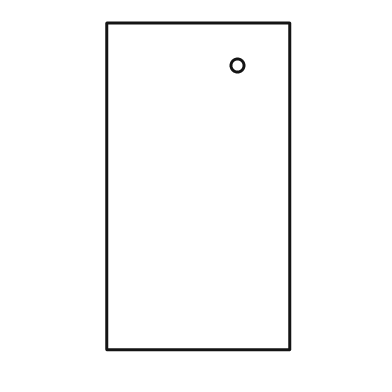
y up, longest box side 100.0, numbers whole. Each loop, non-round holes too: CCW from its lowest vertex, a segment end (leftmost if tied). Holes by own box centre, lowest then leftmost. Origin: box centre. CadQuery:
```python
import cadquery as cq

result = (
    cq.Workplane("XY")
    .moveTo(-28.0, -50.0)
    .lineTo(28.0, -50.0)
    .lineTo(28.0, 50.0)
    .lineTo(-28.0, 50.0)
    .close()
    .moveTo(12.0, 37.0)
    .circle(2.0)
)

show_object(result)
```